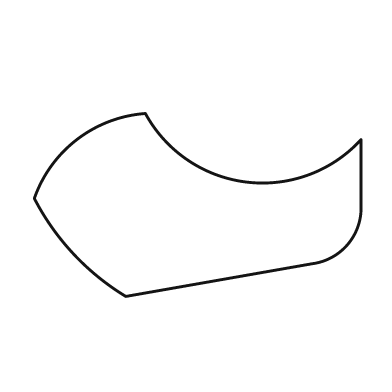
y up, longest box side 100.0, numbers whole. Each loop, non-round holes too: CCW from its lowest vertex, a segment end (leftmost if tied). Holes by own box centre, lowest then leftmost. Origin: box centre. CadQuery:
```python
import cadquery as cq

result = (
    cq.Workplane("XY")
    .moveTo(-22.0, -28.0)
    .lineTo(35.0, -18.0)
    .threePointArc((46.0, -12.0), (50.0, 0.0))
    .lineTo(50.0, 20.0)
    .threePointArc((15.0, 7.0), (-16.0, 28.0))
    .threePointArc((-37.0, 20.0), (-50.0, 2.0))
    .threePointArc((-38.0, -15.0), (-22.0, -28.0))
    .close()
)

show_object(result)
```